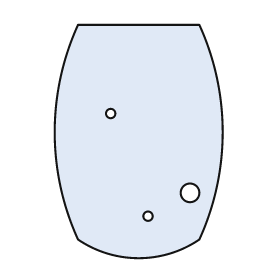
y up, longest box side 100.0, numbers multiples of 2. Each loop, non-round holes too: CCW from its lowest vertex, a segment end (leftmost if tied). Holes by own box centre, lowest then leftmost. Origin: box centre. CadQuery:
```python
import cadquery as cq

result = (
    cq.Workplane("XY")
    .moveTo(-26.0, -42.0)
    .threePointArc((0.0, -50.0), (26.0, -42.0))
    .threePointArc((36.0, 4.0), (26.0, 50.0))
    .lineTo(-26.0, 50.0)
    .threePointArc((-36.0, 4.0), (-26.0, -42.0))
    .close()
    .moveTo(4.0, -32.0)
    .circle(2.0)
    .moveTo(22.0, -22.0)
    .circle(4.0)
    .moveTo(-12.0, 12.0)
    .circle(2.0)
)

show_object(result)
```